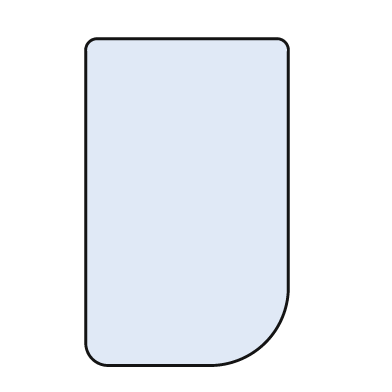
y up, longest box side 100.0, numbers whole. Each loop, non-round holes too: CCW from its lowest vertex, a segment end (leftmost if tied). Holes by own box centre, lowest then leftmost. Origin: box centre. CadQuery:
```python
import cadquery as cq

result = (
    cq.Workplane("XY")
    .moveTo(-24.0, -50.0)
    .lineTo(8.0, -50.0)
    .threePointArc((24.0, -43.0), (31.0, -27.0))
    .lineTo(31.0, 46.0)
    .threePointArc((30.0, 49.0), (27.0, 50.0))
    .lineTo(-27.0, 50.0)
    .threePointArc((-30.0, 49.0), (-31.0, 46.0))
    .lineTo(-31.0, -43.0)
    .threePointArc((-29.0, -48.0), (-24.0, -50.0))
    .close()
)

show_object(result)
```